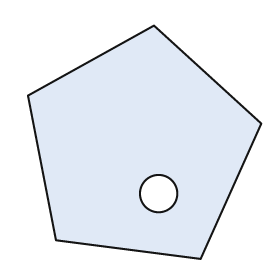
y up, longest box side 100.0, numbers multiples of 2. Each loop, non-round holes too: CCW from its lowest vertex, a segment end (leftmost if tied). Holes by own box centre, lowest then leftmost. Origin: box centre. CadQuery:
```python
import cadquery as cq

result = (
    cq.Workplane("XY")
    .moveTo(24.0, -50.0)
    .lineTo(50.0, 8.0)
    .lineTo(4.0, 50.0)
    .lineTo(-50.0, 20.0)
    .lineTo(-38.0, -42.0)
    .close()
    .moveTo(6.0, -22.0)
    .circle(8.0)
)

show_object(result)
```